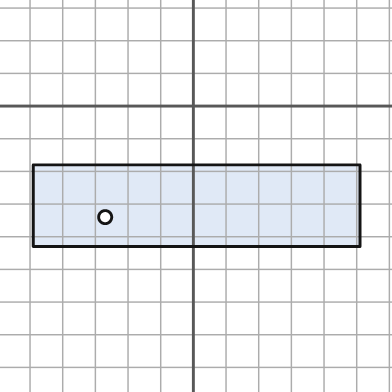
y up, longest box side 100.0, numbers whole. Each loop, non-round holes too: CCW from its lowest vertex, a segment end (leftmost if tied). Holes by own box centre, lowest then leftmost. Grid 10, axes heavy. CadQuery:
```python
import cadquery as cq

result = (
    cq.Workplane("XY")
    .moveTo(-49.0, -43.0)
    .lineTo(51.0, -43.0)
    .lineTo(51.0, -18.0)
    .lineTo(-49.0, -18.0)
    .close()
    .moveTo(-27.0, -34.0)
    .circle(2.0)
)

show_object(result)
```